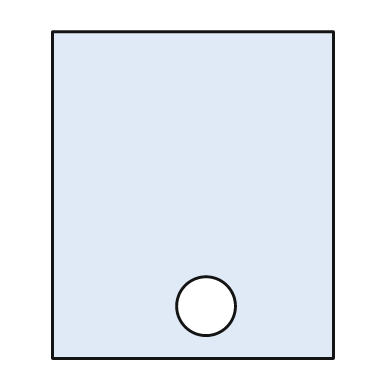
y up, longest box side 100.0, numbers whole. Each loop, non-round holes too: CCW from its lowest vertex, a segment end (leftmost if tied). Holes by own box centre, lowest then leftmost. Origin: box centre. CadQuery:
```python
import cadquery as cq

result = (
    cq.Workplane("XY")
    .moveTo(-43.0, -50.0)
    .lineTo(43.0, -50.0)
    .lineTo(43.0, 50.0)
    .lineTo(-43.0, 50.0)
    .close()
    .moveTo(4.0, -34.0)
    .circle(9.0)
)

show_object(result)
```